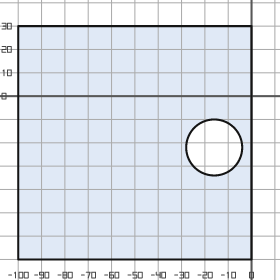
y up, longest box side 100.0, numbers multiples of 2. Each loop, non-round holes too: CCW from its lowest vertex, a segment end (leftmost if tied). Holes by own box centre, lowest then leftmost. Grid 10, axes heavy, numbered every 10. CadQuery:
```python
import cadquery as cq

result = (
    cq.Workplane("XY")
    .moveTo(-100.0, -70.0)
    .lineTo(0.0, -70.0)
    .lineTo(0.0, 30.0)
    .lineTo(-100.0, 30.0)
    .close()
    .moveTo(-16.0, -22.0)
    .circle(12.0)
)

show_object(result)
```